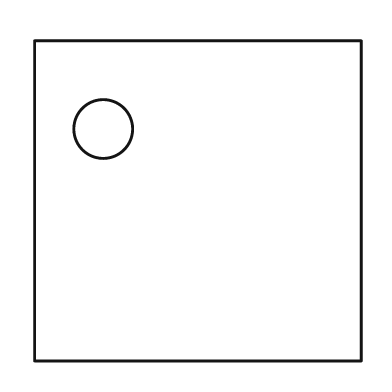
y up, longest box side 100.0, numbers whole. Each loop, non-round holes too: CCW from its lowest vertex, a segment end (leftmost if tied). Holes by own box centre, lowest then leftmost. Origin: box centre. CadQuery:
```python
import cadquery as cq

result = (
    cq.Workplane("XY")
    .moveTo(-50.0, -49.0)
    .lineTo(50.0, -49.0)
    .lineTo(50.0, 49.0)
    .lineTo(-50.0, 49.0)
    .close()
    .moveTo(-29.0, 22.0)
    .circle(9.0)
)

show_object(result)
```